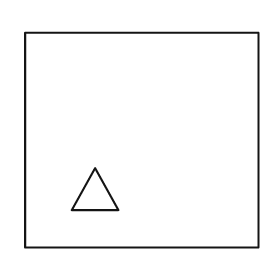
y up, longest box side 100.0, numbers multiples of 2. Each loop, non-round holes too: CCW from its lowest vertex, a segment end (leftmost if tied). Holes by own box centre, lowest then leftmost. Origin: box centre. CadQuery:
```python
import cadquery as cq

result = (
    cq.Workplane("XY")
    .moveTo(-50.0, -46.0)
    .lineTo(50.0, -46.0)
    .lineTo(50.0, 46.0)
    .lineTo(-50.0, 46.0)
    .close()
    .moveTo(-30.0, -30.0)
    .lineTo(-10.0, -30.0)
    .lineTo(-20.0, -12.0)
    .close()
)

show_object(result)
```